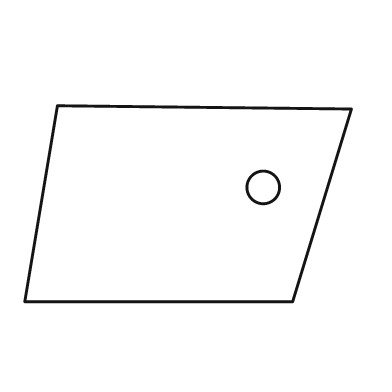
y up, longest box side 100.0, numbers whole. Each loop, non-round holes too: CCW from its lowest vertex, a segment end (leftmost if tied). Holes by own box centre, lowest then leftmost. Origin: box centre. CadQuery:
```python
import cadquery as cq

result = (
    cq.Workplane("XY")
    .moveTo(-50.0, -30.0)
    .lineTo(32.0, -30.0)
    .lineTo(50.0, 29.0)
    .lineTo(-40.0, 30.0)
    .close()
    .moveTo(23.0, 5.0)
    .circle(5.0)
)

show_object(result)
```